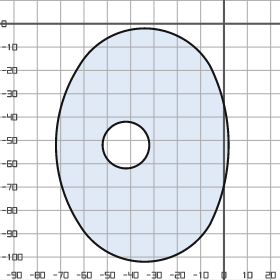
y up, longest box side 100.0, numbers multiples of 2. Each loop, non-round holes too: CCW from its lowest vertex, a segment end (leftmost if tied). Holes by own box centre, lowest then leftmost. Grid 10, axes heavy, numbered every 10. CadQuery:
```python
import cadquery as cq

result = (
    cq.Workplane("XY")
    .moveTo(-62.0, -86.0)
    .threePointArc((-34.0, -102.0), (-6.0, -86.0))
    .threePointArc((2.0, -52.0), (-6.0, -18.0))
    .threePointArc((-34.0, -2.0), (-62.0, -18.0))
    .threePointArc((-72.0, -52.0), (-62.0, -86.0))
    .close()
    .moveTo(-42.0, -52.0)
    .circle(10.0)
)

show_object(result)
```